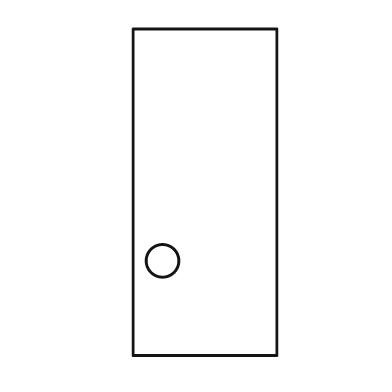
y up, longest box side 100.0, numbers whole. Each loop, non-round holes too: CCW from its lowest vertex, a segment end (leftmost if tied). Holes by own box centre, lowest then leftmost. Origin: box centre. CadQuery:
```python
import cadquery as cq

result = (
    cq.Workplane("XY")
    .moveTo(-22.0, -50.0)
    .lineTo(22.0, -50.0)
    .lineTo(22.0, 50.0)
    .lineTo(-22.0, 50.0)
    .close()
    .moveTo(-13.0, -21.0)
    .circle(5.0)
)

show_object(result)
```